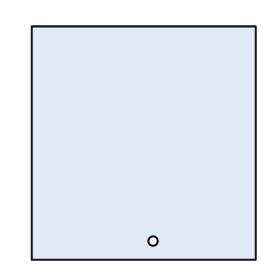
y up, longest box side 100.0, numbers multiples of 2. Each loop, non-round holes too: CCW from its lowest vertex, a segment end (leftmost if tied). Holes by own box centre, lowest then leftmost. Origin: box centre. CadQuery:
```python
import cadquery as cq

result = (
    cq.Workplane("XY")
    .moveTo(-48.0, -50.0)
    .lineTo(48.0, -50.0)
    .lineTo(48.0, 50.0)
    .lineTo(-48.0, 50.0)
    .close()
    .moveTo(4.0, -42.0)
    .circle(2.0)
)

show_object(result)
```